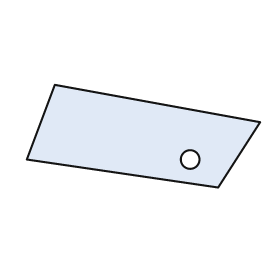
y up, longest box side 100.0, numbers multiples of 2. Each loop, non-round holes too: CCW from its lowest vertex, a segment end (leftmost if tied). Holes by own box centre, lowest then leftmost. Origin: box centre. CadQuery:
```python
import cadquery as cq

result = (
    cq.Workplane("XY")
    .moveTo(32.0, -22.0)
    .lineTo(50.0, 6.0)
    .lineTo(-38.0, 22.0)
    .lineTo(-50.0, -10.0)
    .close()
    .moveTo(20.0, -10.0)
    .circle(4.0)
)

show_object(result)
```